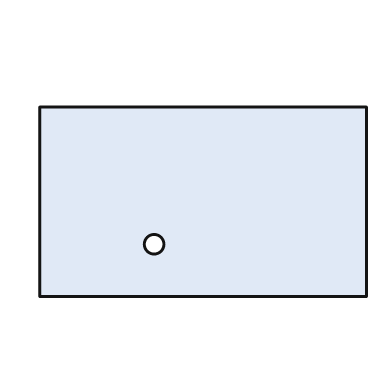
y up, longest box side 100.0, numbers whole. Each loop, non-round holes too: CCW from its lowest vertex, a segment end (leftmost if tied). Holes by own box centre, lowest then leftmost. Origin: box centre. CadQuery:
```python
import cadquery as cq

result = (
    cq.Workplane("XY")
    .moveTo(-50.0, -29.0)
    .lineTo(50.0, -29.0)
    .lineTo(50.0, 29.0)
    .lineTo(-50.0, 29.0)
    .close()
    .moveTo(-15.0, -13.0)
    .circle(3.0)
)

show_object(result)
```